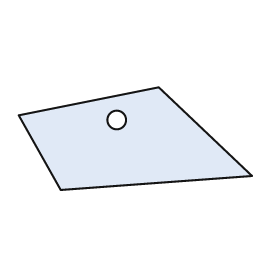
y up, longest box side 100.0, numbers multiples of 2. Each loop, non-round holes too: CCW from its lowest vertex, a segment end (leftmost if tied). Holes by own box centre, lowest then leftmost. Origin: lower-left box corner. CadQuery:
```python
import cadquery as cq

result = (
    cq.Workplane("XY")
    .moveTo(18.0, 0.0)
    .lineTo(100.0, 6.0)
    .lineTo(60.0, 44.0)
    .lineTo(0.0, 32.0)
    .close()
    .moveTo(42.0, 30.0)
    .circle(4.0)
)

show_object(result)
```